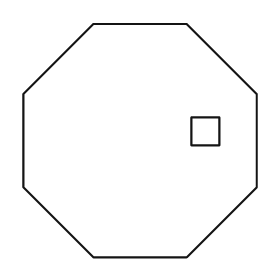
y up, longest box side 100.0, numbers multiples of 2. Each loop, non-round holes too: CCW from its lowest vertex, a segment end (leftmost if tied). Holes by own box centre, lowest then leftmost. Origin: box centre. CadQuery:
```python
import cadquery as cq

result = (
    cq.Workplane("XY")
    .moveTo(-20.0, -50.0)
    .lineTo(20.0, -50.0)
    .lineTo(50.0, -20.0)
    .lineTo(50.0, 20.0)
    .lineTo(20.0, 50.0)
    .lineTo(-20.0, 50.0)
    .lineTo(-50.0, 20.0)
    .lineTo(-50.0, -20.0)
    .close()
    .moveTo(22.0, -2.0)
    .lineTo(34.0, -2.0)
    .lineTo(34.0, 10.0)
    .lineTo(22.0, 10.0)
    .close()
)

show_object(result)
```